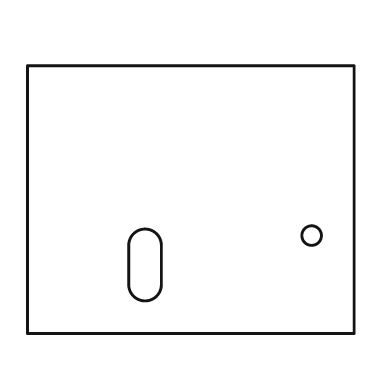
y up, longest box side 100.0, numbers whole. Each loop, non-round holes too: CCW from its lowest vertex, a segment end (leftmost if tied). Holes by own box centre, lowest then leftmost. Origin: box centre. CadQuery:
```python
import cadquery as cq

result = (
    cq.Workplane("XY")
    .moveTo(-50.0, -41.0)
    .lineTo(50.0, -41.0)
    .lineTo(50.0, 41.0)
    .lineTo(-50.0, 41.0)
    .close()
    .moveTo(-19.0, -26.0)
    .threePointArc((-14.0, -31.0), (-9.0, -26.0))
    .lineTo(-9.0, -14.0)
    .threePointArc((-14.0, -9.0), (-19.0, -14.0))
    .close()
    .moveTo(37.0, -11.0)
    .circle(3.0)
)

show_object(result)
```